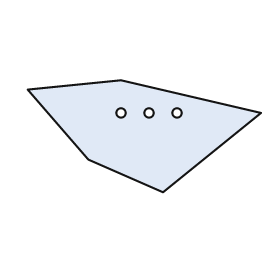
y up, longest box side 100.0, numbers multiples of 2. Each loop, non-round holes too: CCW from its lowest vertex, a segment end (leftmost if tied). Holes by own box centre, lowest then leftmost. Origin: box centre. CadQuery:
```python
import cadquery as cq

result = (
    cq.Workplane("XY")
    .moveTo(8.0, -24.0)
    .lineTo(50.0, 10.0)
    .lineTo(-10.0, 24.0)
    .lineTo(-50.0, 20.0)
    .lineTo(-24.0, -10.0)
    .close()
    .moveTo(-10.0, 10.0)
    .circle(2.0)
    .moveTo(2.0, 10.0)
    .circle(2.0)
    .moveTo(14.0, 10.0)
    .circle(2.0)
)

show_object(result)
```